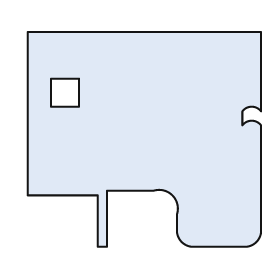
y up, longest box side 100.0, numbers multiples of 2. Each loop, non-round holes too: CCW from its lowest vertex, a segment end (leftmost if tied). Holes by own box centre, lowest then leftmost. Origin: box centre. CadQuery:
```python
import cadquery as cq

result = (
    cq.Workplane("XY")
    .moveTo(-20.0, -46.0)
    .lineTo(-16.0, -46.0)
    .lineTo(-16.0, -22.0)
    .lineTo(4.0, -22.0)
    .threePointArc((12.0, -24.0), (14.0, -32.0))
    .lineTo(14.0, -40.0)
    .threePointArc((16.0, -44.0), (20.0, -46.0))
    .lineTo(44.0, -46.0)
    .threePointArc((48.0, -44.0), (50.0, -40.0))
    .lineTo(50.0, 6.0)
    .threePointArc((46.0, 8.0), (42.0, 6.0))
    .lineTo(42.0, 12.0)
    .threePointArc((46.0, 14.0), (50.0, 12.0))
    .lineTo(50.0, 46.0)
    .lineTo(-50.0, 46.0)
    .lineTo(-50.0, -24.0)
    .lineTo(-20.0, -24.0)
    .close()
    .moveTo(-40.0, 14.0)
    .lineTo(-28.0, 14.0)
    .lineTo(-28.0, 26.0)
    .lineTo(-40.0, 26.0)
    .close()
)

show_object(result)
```